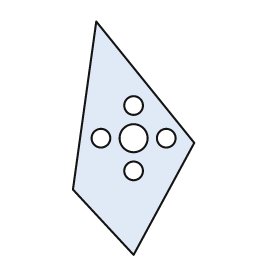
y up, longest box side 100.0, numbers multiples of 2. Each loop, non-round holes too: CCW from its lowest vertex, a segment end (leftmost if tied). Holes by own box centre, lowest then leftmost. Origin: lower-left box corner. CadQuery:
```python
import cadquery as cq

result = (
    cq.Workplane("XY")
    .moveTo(26.0, 0.0)
    .lineTo(52.0, 48.0)
    .lineTo(10.0, 100.0)
    .lineTo(0.0, 28.0)
    .close()
    .moveTo(26.0, 36.0)
    .circle(4.0)
    .moveTo(12.0, 50.0)
    .circle(4.0)
    .moveTo(26.0, 50.0)
    .circle(6.0)
    .moveTo(40.0, 50.0)
    .circle(4.0)
    .moveTo(26.0, 64.0)
    .circle(4.0)
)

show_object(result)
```